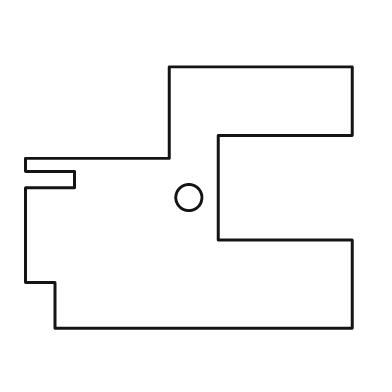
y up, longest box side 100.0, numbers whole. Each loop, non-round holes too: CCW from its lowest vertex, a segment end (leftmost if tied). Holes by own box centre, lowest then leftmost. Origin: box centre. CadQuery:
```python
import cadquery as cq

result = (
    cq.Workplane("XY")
    .moveTo(-41.0, -40.0)
    .lineTo(50.0, -40.0)
    .lineTo(50.0, -13.0)
    .lineTo(9.0, -13.0)
    .lineTo(9.0, 19.0)
    .lineTo(50.0, 19.0)
    .lineTo(50.0, 40.0)
    .lineTo(-6.0, 40.0)
    .lineTo(-6.0, 12.0)
    .lineTo(-50.0, 12.0)
    .lineTo(-50.0, 8.0)
    .lineTo(-35.0, 8.0)
    .lineTo(-35.0, 3.0)
    .lineTo(-50.0, 3.0)
    .lineTo(-50.0, -26.0)
    .lineTo(-41.0, -26.0)
    .close()
    .moveTo(0.0, 0.0)
    .circle(4.0)
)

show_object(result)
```